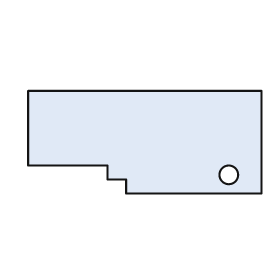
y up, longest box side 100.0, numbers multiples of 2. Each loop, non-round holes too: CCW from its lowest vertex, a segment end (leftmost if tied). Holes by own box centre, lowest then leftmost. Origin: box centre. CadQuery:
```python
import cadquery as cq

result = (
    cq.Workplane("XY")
    .moveTo(-8.0, -22.0)
    .lineTo(50.0, -22.0)
    .lineTo(50.0, 22.0)
    .lineTo(-50.0, 22.0)
    .lineTo(-50.0, -10.0)
    .lineTo(-16.0, -10.0)
    .lineTo(-16.0, -16.0)
    .lineTo(-8.0, -16.0)
    .close()
    .moveTo(36.0, -14.0)
    .circle(4.0)
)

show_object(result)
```